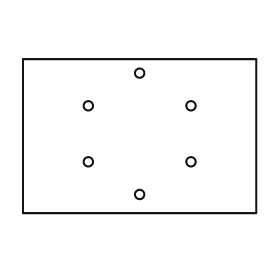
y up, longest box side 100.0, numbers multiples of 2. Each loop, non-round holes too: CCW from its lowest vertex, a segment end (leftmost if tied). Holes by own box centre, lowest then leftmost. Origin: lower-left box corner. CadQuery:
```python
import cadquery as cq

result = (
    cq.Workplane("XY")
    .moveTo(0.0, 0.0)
    .lineTo(100.0, 0.0)
    .lineTo(100.0, 66.0)
    .lineTo(0.0, 66.0)
    .close()
    .moveTo(50.0, 8.0)
    .circle(2.0)
    .moveTo(28.0, 22.0)
    .circle(2.0)
    .moveTo(72.0, 22.0)
    .circle(2.0)
    .moveTo(28.0, 46.0)
    .circle(2.0)
    .moveTo(72.0, 46.0)
    .circle(2.0)
    .moveTo(50.0, 60.0)
    .circle(2.0)
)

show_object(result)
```